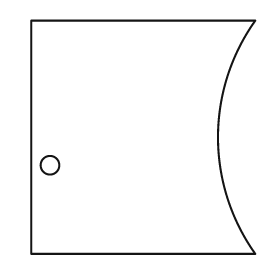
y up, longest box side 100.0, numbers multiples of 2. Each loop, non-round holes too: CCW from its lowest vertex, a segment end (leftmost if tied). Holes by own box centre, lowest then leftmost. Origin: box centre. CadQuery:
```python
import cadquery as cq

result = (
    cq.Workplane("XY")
    .moveTo(-48.0, -50.0)
    .lineTo(48.0, -50.0)
    .threePointArc((32.0, 0.0), (48.0, 50.0))
    .lineTo(-48.0, 50.0)
    .close()
    .moveTo(-40.0, -12.0)
    .circle(4.0)
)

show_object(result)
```